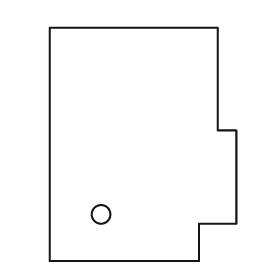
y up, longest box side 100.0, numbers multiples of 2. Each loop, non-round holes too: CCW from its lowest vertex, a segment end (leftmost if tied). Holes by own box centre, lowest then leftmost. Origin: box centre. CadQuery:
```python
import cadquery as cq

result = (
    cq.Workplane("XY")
    .moveTo(-40.0, -50.0)
    .lineTo(24.0, -50.0)
    .lineTo(24.0, -34.0)
    .lineTo(40.0, -34.0)
    .lineTo(40.0, 6.0)
    .lineTo(32.0, 6.0)
    .lineTo(32.0, 50.0)
    .lineTo(-40.0, 50.0)
    .close()
    .moveTo(-18.0, -30.0)
    .circle(4.0)
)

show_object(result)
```